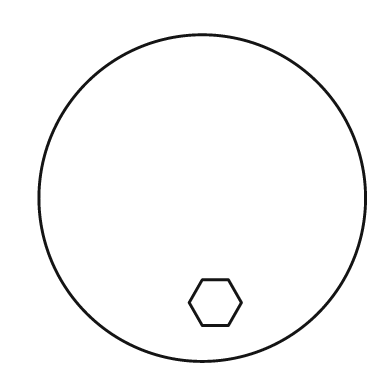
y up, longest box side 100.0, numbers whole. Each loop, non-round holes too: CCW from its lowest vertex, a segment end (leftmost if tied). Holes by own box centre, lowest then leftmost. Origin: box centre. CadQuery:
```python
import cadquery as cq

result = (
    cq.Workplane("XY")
    .moveTo(0.0, 0.0)
    .circle(50.0)
    .moveTo(0.0, -39.0)
    .lineTo(8.0, -39.0)
    .lineTo(12.0, -32.0)
    .lineTo(8.0, -25.0)
    .lineTo(0.0, -25.0)
    .lineTo(-4.0, -32.0)
    .close()
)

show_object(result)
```